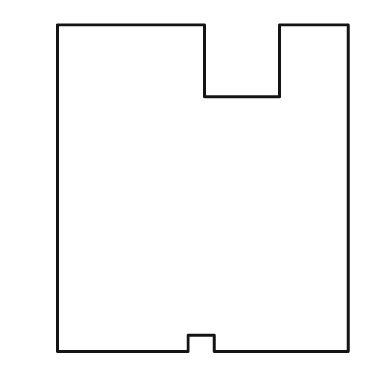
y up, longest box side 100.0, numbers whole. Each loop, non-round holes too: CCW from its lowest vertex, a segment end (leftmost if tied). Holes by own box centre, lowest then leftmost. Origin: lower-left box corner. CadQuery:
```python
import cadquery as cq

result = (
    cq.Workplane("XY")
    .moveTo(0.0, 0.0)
    .lineTo(40.0, 0.0)
    .lineTo(40.0, 5.0)
    .lineTo(48.0, 5.0)
    .lineTo(48.0, 0.0)
    .lineTo(89.0, 0.0)
    .lineTo(89.0, 100.0)
    .lineTo(68.0, 100.0)
    .lineTo(68.0, 78.0)
    .lineTo(45.0, 78.0)
    .lineTo(45.0, 100.0)
    .lineTo(0.0, 100.0)
    .close()
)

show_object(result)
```